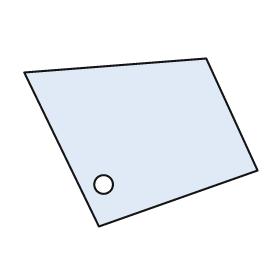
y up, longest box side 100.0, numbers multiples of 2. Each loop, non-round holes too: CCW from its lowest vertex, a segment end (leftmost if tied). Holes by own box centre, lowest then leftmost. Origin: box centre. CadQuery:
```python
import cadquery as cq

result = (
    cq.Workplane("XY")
    .moveTo(-18.0, -36.0)
    .lineTo(50.0, -12.0)
    .lineTo(28.0, 36.0)
    .lineTo(-50.0, 30.0)
    .close()
    .moveTo(-16.0, -18.0)
    .circle(4.0)
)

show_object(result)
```